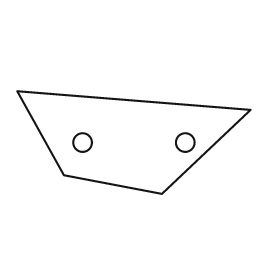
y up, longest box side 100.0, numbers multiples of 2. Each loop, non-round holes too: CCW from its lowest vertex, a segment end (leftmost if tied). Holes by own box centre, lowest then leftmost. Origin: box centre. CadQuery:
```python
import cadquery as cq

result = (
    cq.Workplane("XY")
    .moveTo(12.0, -22.0)
    .lineTo(50.0, 14.0)
    .lineTo(-50.0, 22.0)
    .lineTo(-30.0, -14.0)
    .close()
    .moveTo(-22.0, 0.0)
    .circle(4.0)
    .moveTo(22.0, 0.0)
    .circle(4.0)
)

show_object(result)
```